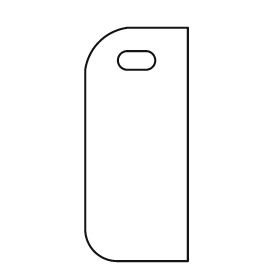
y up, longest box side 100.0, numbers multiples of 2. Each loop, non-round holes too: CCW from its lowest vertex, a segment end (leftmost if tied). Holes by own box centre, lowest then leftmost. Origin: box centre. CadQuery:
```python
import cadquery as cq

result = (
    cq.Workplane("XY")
    .moveTo(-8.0, -50.0)
    .lineTo(22.0, -50.0)
    .lineTo(22.0, 50.0)
    .lineTo(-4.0, 50.0)
    .threePointArc((-16.0, 44.0), (-22.0, 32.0))
    .lineTo(-22.0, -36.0)
    .threePointArc((-18.0, -46.0), (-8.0, -50.0))
    .close()
    .moveTo(-4.0, 32.0)
    .lineTo(4.0, 32.0)
    .threePointArc((8.0, 36.0), (4.0, 40.0))
    .lineTo(-4.0, 40.0)
    .threePointArc((-8.0, 36.0), (-4.0, 32.0))
    .close()
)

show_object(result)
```